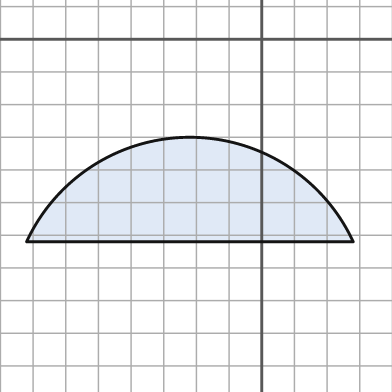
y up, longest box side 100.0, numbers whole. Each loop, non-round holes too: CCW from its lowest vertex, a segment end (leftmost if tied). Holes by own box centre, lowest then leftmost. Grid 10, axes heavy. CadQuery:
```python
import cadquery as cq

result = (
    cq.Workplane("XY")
    .moveTo(-72.0, -62.0)
    .lineTo(28.0, -62.0)
    .threePointArc((-22.0, -30.0), (-72.0, -62.0))
    .close()
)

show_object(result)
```